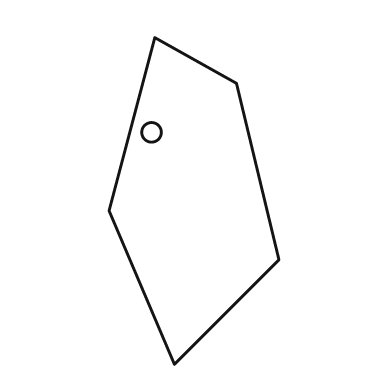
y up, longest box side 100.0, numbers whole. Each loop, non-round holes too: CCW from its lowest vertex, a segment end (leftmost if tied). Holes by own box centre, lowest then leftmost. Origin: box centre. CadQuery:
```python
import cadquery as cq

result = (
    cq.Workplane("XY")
    .moveTo(-6.0, -50.0)
    .lineTo(26.0, -18.0)
    .lineTo(13.0, 36.0)
    .lineTo(-12.0, 50.0)
    .lineTo(-26.0, -3.0)
    .close()
    .moveTo(-13.0, 21.0)
    .circle(3.0)
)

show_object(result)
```